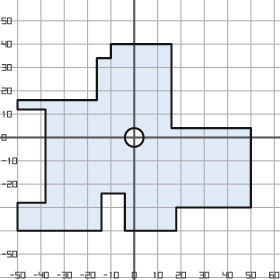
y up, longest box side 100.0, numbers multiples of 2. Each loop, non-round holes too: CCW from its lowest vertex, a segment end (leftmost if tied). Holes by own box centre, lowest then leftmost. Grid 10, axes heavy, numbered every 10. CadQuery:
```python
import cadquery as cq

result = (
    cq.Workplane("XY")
    .moveTo(-50.0, -40.0)
    .lineTo(-14.0, -40.0)
    .lineTo(-14.0, -24.0)
    .lineTo(-4.0, -24.0)
    .lineTo(-4.0, -40.0)
    .lineTo(18.0, -40.0)
    .lineTo(18.0, -30.0)
    .lineTo(50.0, -30.0)
    .lineTo(50.0, 4.0)
    .lineTo(16.0, 4.0)
    .lineTo(16.0, 40.0)
    .lineTo(-10.0, 40.0)
    .lineTo(-10.0, 34.0)
    .lineTo(-16.0, 34.0)
    .lineTo(-16.0, 16.0)
    .lineTo(-50.0, 16.0)
    .lineTo(-50.0, 12.0)
    .lineTo(-38.0, 12.0)
    .lineTo(-38.0, -28.0)
    .lineTo(-50.0, -28.0)
    .close()
    .moveTo(0.0, 0.0)
    .circle(4.0)
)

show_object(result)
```